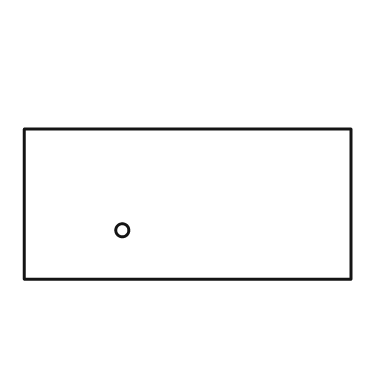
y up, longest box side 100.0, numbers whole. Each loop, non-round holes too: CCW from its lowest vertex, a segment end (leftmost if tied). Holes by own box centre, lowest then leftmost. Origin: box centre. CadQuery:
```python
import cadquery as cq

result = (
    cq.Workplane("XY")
    .moveTo(-50.0, -23.0)
    .lineTo(50.0, -23.0)
    .lineTo(50.0, 23.0)
    .lineTo(-50.0, 23.0)
    .close()
    .moveTo(-20.0, -8.0)
    .circle(2.0)
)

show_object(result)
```